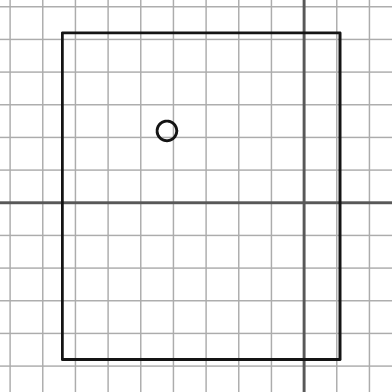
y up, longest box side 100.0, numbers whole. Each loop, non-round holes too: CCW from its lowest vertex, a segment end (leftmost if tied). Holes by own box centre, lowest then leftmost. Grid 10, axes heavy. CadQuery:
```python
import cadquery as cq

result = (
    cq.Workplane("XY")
    .moveTo(-74.0, -48.0)
    .lineTo(11.0, -48.0)
    .lineTo(11.0, 52.0)
    .lineTo(-74.0, 52.0)
    .close()
    .moveTo(-42.0, 22.0)
    .circle(3.0)
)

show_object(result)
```